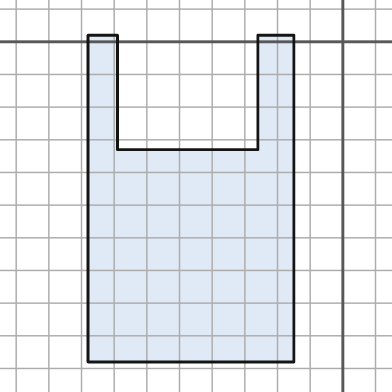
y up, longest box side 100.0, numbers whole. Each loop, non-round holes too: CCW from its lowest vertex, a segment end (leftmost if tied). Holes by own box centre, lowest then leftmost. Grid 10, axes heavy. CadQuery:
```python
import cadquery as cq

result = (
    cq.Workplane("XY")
    .moveTo(-78.0, -98.0)
    .lineTo(-15.0, -98.0)
    .lineTo(-15.0, 2.0)
    .lineTo(-26.0, 2.0)
    .lineTo(-26.0, -33.0)
    .lineTo(-69.0, -33.0)
    .lineTo(-69.0, 2.0)
    .lineTo(-78.0, 2.0)
    .close()
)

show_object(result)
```